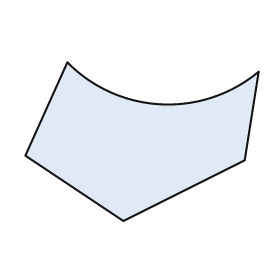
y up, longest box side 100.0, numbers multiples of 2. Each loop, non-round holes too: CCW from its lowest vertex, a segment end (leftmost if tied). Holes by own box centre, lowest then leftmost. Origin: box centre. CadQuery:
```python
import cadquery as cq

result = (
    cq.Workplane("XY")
    .moveTo(-8.0, -34.0)
    .lineTo(44.0, -8.0)
    .lineTo(50.0, 30.0)
    .threePointArc((8.0, 16.0), (-32.0, 34.0))
    .lineTo(-50.0, -6.0)
    .close()
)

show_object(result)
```